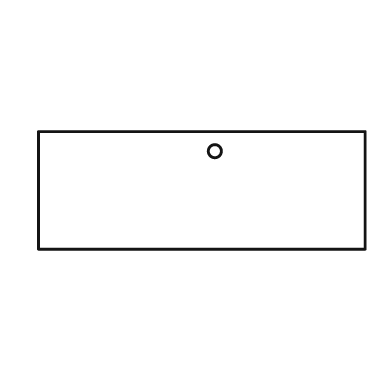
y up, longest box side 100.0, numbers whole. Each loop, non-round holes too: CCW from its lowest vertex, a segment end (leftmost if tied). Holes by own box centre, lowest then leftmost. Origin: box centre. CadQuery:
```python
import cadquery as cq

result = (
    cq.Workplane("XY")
    .moveTo(-50.0, -18.0)
    .lineTo(50.0, -18.0)
    .lineTo(50.0, 18.0)
    .lineTo(-50.0, 18.0)
    .close()
    .moveTo(4.0, 12.0)
    .circle(2.0)
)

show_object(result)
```